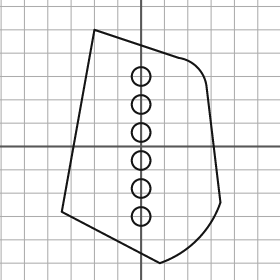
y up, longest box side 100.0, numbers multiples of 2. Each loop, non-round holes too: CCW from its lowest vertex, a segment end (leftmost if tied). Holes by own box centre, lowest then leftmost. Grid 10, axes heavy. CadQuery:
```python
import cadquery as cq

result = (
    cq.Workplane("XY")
    .moveTo(8.0, -50.0)
    .threePointArc((24.0, -40.0), (34.0, -24.0))
    .lineTo(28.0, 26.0)
    .threePointArc((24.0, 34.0), (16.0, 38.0))
    .lineTo(-20.0, 50.0)
    .lineTo(-34.0, -28.0)
    .close()
    .moveTo(0.0, -30.0)
    .circle(4.0)
    .moveTo(0.0, -18.0)
    .circle(4.0)
    .moveTo(0.0, -6.0)
    .circle(4.0)
    .moveTo(0.0, 6.0)
    .circle(4.0)
    .moveTo(0.0, 18.0)
    .circle(4.0)
    .moveTo(0.0, 30.0)
    .circle(4.0)
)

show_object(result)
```